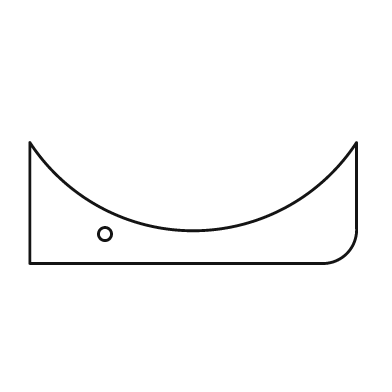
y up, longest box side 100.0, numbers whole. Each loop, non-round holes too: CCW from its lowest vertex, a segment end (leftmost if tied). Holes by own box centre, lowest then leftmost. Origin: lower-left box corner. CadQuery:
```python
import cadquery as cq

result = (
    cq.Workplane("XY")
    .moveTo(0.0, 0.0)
    .lineTo(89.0, 0.0)
    .threePointArc((97.0, 3.0), (100.0, 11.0))
    .lineTo(100.0, 37.0)
    .threePointArc((50.0, 10.0), (0.0, 37.0))
    .close()
    .moveTo(23.0, 9.0)
    .circle(2.0)
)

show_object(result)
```